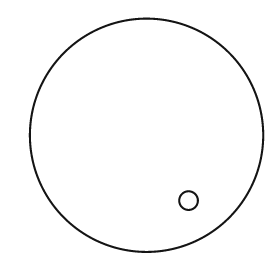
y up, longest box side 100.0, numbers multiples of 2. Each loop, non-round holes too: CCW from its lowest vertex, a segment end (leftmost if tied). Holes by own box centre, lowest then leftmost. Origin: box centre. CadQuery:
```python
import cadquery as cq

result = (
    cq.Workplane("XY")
    .moveTo(0.0, 0.0)
    .circle(50.0)
    .moveTo(18.0, -28.0)
    .circle(4.0)
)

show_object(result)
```